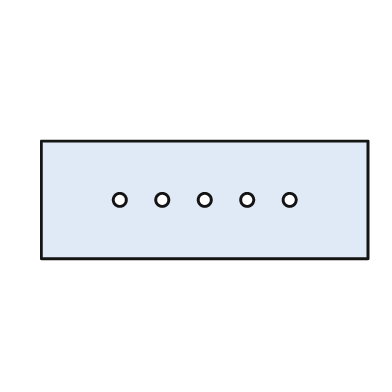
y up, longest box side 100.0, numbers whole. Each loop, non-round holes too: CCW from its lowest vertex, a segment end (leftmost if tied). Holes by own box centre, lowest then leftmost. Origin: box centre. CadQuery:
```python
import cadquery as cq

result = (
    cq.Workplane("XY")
    .moveTo(-50.0, -18.0)
    .lineTo(50.0, -18.0)
    .lineTo(50.0, 18.0)
    .lineTo(-50.0, 18.0)
    .close()
    .moveTo(-26.0, 0.0)
    .circle(2.0)
    .moveTo(-13.0, 0.0)
    .circle(2.0)
    .moveTo(0.0, 0.0)
    .circle(2.0)
    .moveTo(13.0, 0.0)
    .circle(2.0)
    .moveTo(26.0, 0.0)
    .circle(2.0)
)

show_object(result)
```